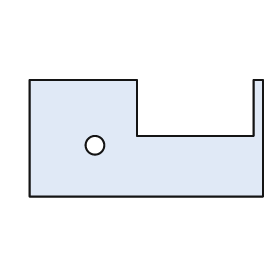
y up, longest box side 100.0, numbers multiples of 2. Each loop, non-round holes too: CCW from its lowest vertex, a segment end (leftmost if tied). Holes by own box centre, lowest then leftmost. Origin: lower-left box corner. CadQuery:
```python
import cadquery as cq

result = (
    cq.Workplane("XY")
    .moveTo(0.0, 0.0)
    .lineTo(100.0, 0.0)
    .lineTo(100.0, 50.0)
    .lineTo(96.0, 50.0)
    .lineTo(96.0, 26.0)
    .lineTo(46.0, 26.0)
    .lineTo(46.0, 50.0)
    .lineTo(0.0, 50.0)
    .close()
    .moveTo(28.0, 22.0)
    .circle(4.0)
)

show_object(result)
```